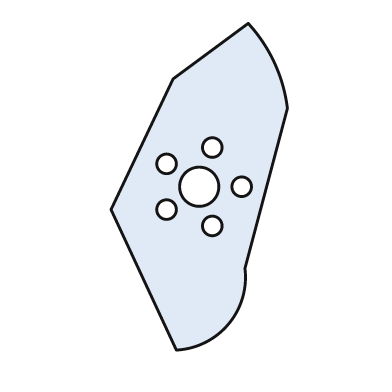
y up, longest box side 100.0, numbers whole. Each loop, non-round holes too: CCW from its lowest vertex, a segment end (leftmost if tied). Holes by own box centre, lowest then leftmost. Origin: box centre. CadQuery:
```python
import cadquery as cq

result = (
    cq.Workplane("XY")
    .moveTo(-7.0, -50.0)
    .threePointArc((9.0, -42.0), (14.0, -25.0))
    .lineTo(27.0, 24.0)
    .threePointArc((23.0, 38.0), (15.0, 50.0))
    .lineTo(-8.0, 33.0)
    .lineTo(-27.0, -7.0)
    .close()
    .moveTo(4.0, -12.0)
    .circle(3.0)
    .moveTo(-10.0, -7.0)
    .circle(3.0)
    .moveTo(0.0, 0.0)
    .circle(6.0)
    .moveTo(13.0, 0.0)
    .circle(3.0)
    .moveTo(-10.0, 7.0)
    .circle(3.0)
    .moveTo(4.0, 12.0)
    .circle(3.0)
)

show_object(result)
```